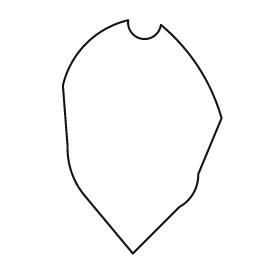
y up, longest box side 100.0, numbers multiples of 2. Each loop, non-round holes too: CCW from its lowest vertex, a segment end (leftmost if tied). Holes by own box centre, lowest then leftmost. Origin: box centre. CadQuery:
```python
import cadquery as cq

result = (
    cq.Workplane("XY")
    .moveTo(-4.0, -50.0)
    .lineTo(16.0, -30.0)
    .threePointArc((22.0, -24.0), (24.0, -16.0))
    .lineTo(34.0, 8.0)
    .threePointArc((24.0, 30.0), (8.0, 48.0))
    .threePointArc((0.0, 42.0), (-6.0, 50.0))
    .threePointArc((-24.0, 40.0), (-34.0, 22.0))
    .lineTo(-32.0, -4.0)
    .threePointArc((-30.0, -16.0), (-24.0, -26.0))
    .close()
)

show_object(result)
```